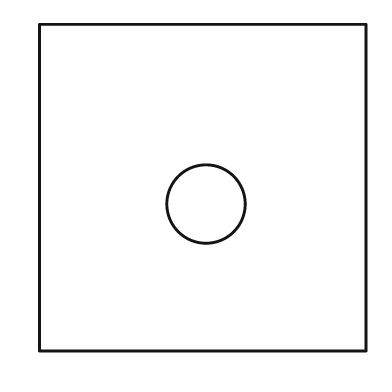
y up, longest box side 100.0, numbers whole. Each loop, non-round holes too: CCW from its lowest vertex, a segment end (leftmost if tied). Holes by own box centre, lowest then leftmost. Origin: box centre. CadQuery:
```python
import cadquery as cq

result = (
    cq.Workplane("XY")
    .moveTo(-50.0, -50.0)
    .lineTo(50.0, -50.0)
    .lineTo(50.0, 50.0)
    .lineTo(-50.0, 50.0)
    .close()
    .moveTo(1.0, -5.0)
    .circle(12.0)
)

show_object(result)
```